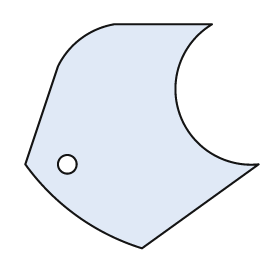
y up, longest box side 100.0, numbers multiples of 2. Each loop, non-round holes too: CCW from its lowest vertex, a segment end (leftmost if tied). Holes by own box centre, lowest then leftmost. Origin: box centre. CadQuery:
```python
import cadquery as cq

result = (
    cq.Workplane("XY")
    .moveTo(0.0, -48.0)
    .lineTo(50.0, -12.0)
    .threePointArc((16.0, 10.0), (30.0, 48.0))
    .lineTo(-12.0, 48.0)
    .threePointArc((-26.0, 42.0), (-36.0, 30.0))
    .lineTo(-50.0, -12.0)
    .threePointArc((-28.0, -34.0), (0.0, -48.0))
    .close()
    .moveTo(-32.0, -12.0)
    .circle(4.0)
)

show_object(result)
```